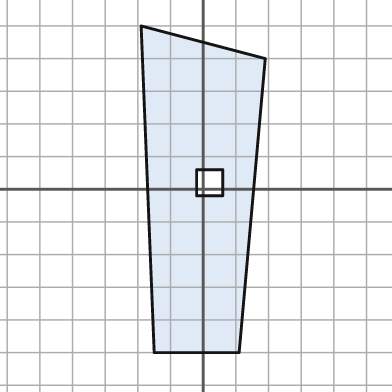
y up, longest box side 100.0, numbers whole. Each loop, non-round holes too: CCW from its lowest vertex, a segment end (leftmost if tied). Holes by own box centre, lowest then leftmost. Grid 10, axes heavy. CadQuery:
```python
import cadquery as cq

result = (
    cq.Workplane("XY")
    .moveTo(-15.0, -50.0)
    .lineTo(11.0, -50.0)
    .lineTo(19.0, 40.0)
    .lineTo(-19.0, 50.0)
    .close()
    .moveTo(-2.0, -2.0)
    .lineTo(6.0, -2.0)
    .lineTo(6.0, 6.0)
    .lineTo(-2.0, 6.0)
    .close()
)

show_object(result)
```